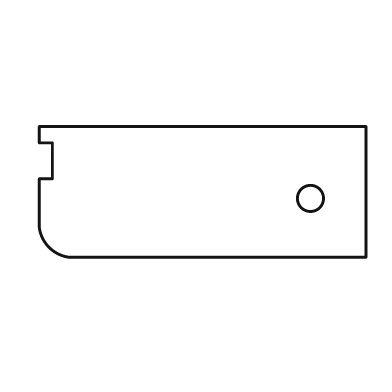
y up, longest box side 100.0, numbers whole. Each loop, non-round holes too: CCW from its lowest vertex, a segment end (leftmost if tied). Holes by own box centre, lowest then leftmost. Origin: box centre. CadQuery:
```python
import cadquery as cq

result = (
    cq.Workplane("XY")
    .moveTo(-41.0, -20.0)
    .lineTo(50.0, -20.0)
    .lineTo(50.0, 20.0)
    .lineTo(-50.0, 20.0)
    .lineTo(-50.0, 15.0)
    .lineTo(-46.0, 15.0)
    .lineTo(-46.0, 4.0)
    .lineTo(-50.0, 4.0)
    .lineTo(-50.0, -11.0)
    .threePointArc((-47.0, -17.0), (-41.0, -20.0))
    .close()
    .moveTo(33.0, -2.0)
    .circle(4.0)
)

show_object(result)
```